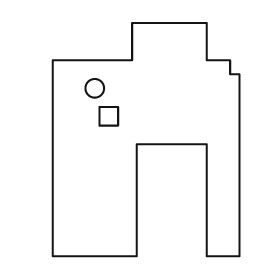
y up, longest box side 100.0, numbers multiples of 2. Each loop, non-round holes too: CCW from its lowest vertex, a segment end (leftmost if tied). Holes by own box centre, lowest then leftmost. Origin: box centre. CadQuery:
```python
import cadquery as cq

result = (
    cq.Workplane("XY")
    .moveTo(-40.0, -50.0)
    .lineTo(-4.0, -50.0)
    .lineTo(-4.0, -2.0)
    .lineTo(26.0, -2.0)
    .lineTo(26.0, -50.0)
    .lineTo(40.0, -50.0)
    .lineTo(40.0, 28.0)
    .lineTo(36.0, 28.0)
    .lineTo(36.0, 34.0)
    .lineTo(26.0, 34.0)
    .lineTo(26.0, 50.0)
    .lineTo(-6.0, 50.0)
    .lineTo(-6.0, 34.0)
    .lineTo(-40.0, 34.0)
    .close()
    .moveTo(-20.0, 6.0)
    .lineTo(-12.0, 6.0)
    .lineTo(-12.0, 14.0)
    .lineTo(-20.0, 14.0)
    .close()
    .moveTo(-22.0, 22.0)
    .circle(4.0)
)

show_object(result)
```